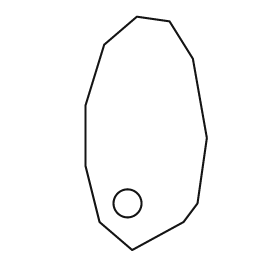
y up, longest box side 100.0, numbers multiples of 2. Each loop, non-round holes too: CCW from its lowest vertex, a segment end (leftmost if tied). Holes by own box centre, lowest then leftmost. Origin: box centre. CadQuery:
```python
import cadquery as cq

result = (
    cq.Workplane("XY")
    .moveTo(-6.0, -50.0)
    .lineTo(16.0, -38.0)
    .lineTo(22.0, -30.0)
    .lineTo(26.0, -2.0)
    .lineTo(20.0, 32.0)
    .lineTo(10.0, 48.0)
    .lineTo(-4.0, 50.0)
    .lineTo(-18.0, 38.0)
    .lineTo(-26.0, 12.0)
    .lineTo(-26.0, -14.0)
    .lineTo(-20.0, -38.0)
    .close()
    .moveTo(-8.0, -30.0)
    .circle(6.0)
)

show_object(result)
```